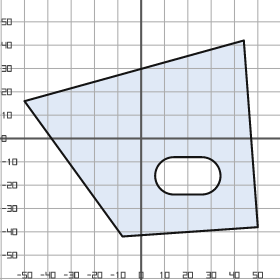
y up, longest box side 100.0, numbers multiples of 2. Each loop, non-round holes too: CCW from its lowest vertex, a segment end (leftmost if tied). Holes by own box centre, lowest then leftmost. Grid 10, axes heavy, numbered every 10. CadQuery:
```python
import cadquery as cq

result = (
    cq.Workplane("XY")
    .moveTo(-8.0, -42.0)
    .lineTo(50.0, -38.0)
    .lineTo(44.0, 42.0)
    .lineTo(-50.0, 16.0)
    .close()
    .moveTo(14.0, -24.0)
    .lineTo(26.0, -24.0)
    .threePointArc((34.0, -16.0), (26.0, -8.0))
    .lineTo(14.0, -8.0)
    .threePointArc((6.0, -16.0), (14.0, -24.0))
    .close()
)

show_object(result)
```